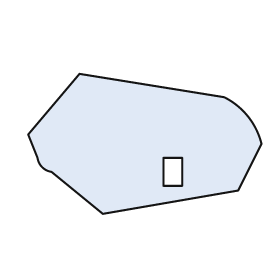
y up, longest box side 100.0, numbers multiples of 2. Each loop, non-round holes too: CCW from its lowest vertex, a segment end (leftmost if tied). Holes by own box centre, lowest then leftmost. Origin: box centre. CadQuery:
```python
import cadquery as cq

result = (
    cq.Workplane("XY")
    .moveTo(-18.0, -30.0)
    .lineTo(40.0, -20.0)
    .lineTo(50.0, 0.0)
    .threePointArc((44.0, 12.0), (34.0, 20.0))
    .lineTo(-28.0, 30.0)
    .lineTo(-50.0, 4.0)
    .lineTo(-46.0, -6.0)
    .threePointArc((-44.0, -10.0), (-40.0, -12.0))
    .close()
    .moveTo(8.0, -18.0)
    .lineTo(16.0, -18.0)
    .lineTo(16.0, -6.0)
    .lineTo(8.0, -6.0)
    .close()
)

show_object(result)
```